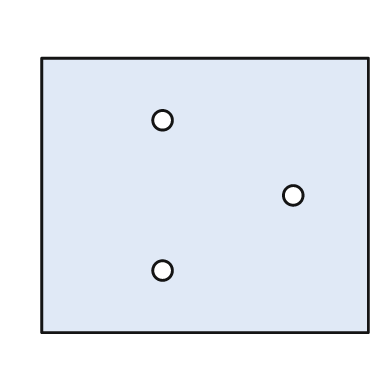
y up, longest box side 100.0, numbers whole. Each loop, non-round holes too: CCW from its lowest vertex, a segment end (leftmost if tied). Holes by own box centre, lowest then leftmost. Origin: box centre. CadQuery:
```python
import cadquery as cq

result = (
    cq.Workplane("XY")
    .moveTo(-50.0, -42.0)
    .lineTo(50.0, -42.0)
    .lineTo(50.0, 42.0)
    .lineTo(-50.0, 42.0)
    .close()
    .moveTo(-13.0, -23.0)
    .circle(3.0)
    .moveTo(27.0, 0.0)
    .circle(3.0)
    .moveTo(-13.0, 23.0)
    .circle(3.0)
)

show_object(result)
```